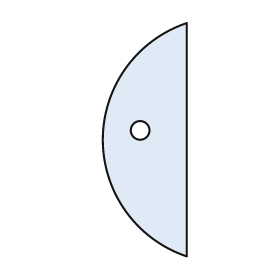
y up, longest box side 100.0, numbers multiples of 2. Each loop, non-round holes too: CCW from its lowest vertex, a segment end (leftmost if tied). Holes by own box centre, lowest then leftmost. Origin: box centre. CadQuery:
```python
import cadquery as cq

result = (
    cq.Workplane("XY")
    .moveTo(18.0, -50.0)
    .lineTo(18.0, 50.0)
    .threePointArc((-18.0, 0.0), (18.0, -50.0))
    .close()
    .moveTo(-2.0, 4.0)
    .circle(4.0)
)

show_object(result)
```